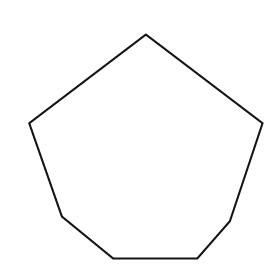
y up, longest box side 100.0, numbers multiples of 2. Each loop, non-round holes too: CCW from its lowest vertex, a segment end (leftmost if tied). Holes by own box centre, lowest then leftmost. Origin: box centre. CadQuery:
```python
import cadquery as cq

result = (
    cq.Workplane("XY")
    .moveTo(-14.0, -48.0)
    .lineTo(22.0, -48.0)
    .lineTo(36.0, -32.0)
    .lineTo(50.0, 10.0)
    .lineTo(0.0, 48.0)
    .lineTo(-50.0, 10.0)
    .lineTo(-36.0, -30.0)
    .close()
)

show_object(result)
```